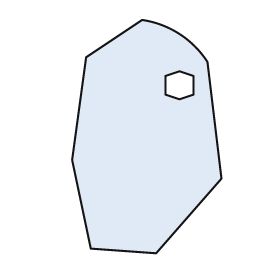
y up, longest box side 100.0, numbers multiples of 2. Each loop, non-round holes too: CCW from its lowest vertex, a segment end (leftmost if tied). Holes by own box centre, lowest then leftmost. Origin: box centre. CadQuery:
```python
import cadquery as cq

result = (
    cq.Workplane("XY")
    .moveTo(4.0, -50.0)
    .lineTo(32.0, -18.0)
    .lineTo(26.0, 32.0)
    .threePointArc((14.0, 44.0), (-2.0, 50.0))
    .lineTo(-26.0, 34.0)
    .lineTo(-32.0, -10.0)
    .lineTo(-24.0, -48.0)
    .close()
    .moveTo(14.0, 16.0)
    .lineTo(20.0, 18.0)
    .lineTo(20.0, 26.0)
    .lineTo(14.0, 28.0)
    .lineTo(8.0, 26.0)
    .lineTo(8.0, 18.0)
    .close()
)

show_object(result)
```